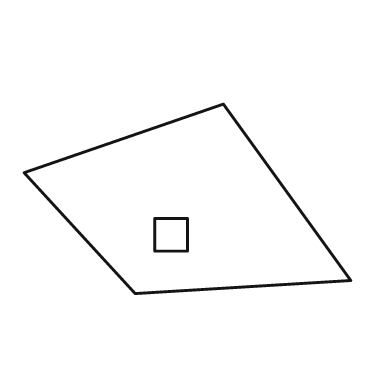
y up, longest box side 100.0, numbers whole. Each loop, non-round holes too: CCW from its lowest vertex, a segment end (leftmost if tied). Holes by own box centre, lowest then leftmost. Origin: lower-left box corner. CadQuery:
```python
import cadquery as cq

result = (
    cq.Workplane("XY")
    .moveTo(34.0, 0.0)
    .lineTo(100.0, 4.0)
    .lineTo(61.0, 58.0)
    .lineTo(0.0, 37.0)
    .close()
    .moveTo(40.0, 13.0)
    .lineTo(50.0, 13.0)
    .lineTo(50.0, 23.0)
    .lineTo(40.0, 23.0)
    .close()
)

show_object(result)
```